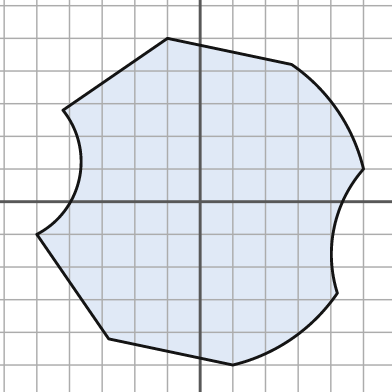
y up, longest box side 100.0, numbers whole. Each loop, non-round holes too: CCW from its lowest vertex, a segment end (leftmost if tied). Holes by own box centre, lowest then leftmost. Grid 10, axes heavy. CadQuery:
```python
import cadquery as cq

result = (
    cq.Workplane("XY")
    .moveTo(10.0, -50.0)
    .threePointArc((28.0, -42.0), (42.0, -28.0))
    .threePointArc((41.0, -8.0), (50.0, 10.0))
    .threePointArc((42.0, 28.0), (28.0, 42.0))
    .lineTo(-10.0, 50.0)
    .lineTo(-42.0, 28.0)
    .threePointArc((-37.0, 7.0), (-50.0, -10.0))
    .lineTo(-28.0, -42.0)
    .close()
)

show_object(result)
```